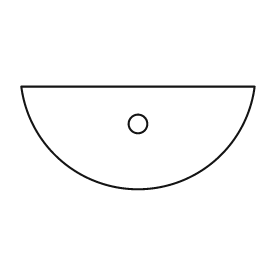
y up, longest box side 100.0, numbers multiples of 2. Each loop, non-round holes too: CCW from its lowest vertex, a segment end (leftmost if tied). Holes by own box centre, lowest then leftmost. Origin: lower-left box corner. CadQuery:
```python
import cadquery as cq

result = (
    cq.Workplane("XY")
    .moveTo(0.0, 44.0)
    .threePointArc((50.0, 0.0), (100.0, 44.0))
    .close()
    .moveTo(50.0, 28.0)
    .circle(4.0)
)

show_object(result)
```